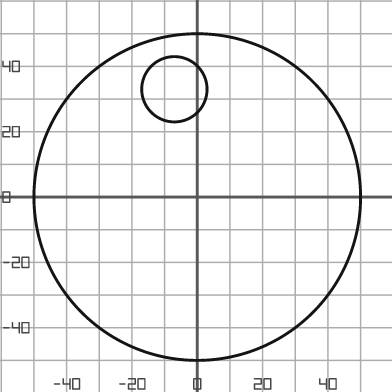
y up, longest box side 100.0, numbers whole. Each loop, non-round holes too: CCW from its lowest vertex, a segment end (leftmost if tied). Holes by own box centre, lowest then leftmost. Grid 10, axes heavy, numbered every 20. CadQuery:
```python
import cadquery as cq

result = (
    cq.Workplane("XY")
    .moveTo(0.0, 0.0)
    .circle(50.0)
    .moveTo(-7.0, 33.0)
    .circle(10.0)
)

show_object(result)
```